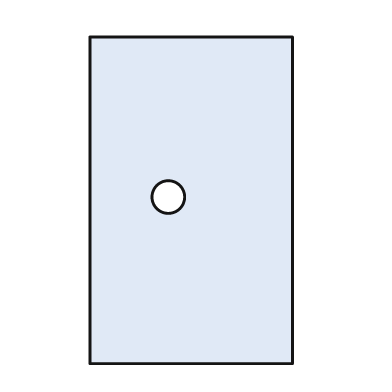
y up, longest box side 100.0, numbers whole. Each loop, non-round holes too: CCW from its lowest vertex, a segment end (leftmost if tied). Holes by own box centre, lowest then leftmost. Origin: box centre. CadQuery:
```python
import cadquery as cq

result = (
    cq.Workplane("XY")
    .moveTo(-31.0, -50.0)
    .lineTo(31.0, -50.0)
    .lineTo(31.0, 50.0)
    .lineTo(-31.0, 50.0)
    .close()
    .moveTo(-7.0, 1.0)
    .circle(5.0)
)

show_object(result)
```